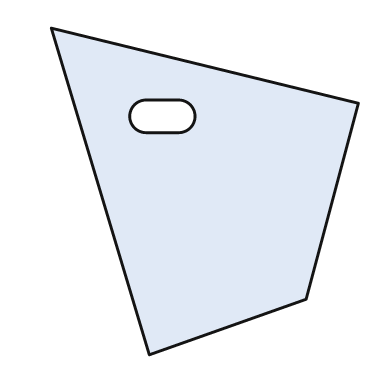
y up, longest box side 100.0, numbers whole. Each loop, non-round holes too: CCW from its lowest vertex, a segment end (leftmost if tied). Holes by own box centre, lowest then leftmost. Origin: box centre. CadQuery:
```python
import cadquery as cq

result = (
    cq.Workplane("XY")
    .moveTo(-17.0, -50.0)
    .lineTo(31.0, -33.0)
    .lineTo(47.0, 27.0)
    .lineTo(-47.0, 50.0)
    .close()
    .moveTo(-18.0, 18.0)
    .lineTo(-8.0, 18.0)
    .threePointArc((-3.0, 23.0), (-8.0, 28.0))
    .lineTo(-18.0, 28.0)
    .threePointArc((-23.0, 23.0), (-18.0, 18.0))
    .close()
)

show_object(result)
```